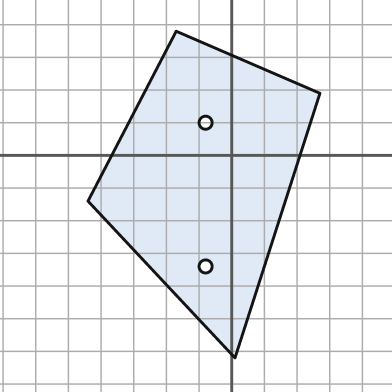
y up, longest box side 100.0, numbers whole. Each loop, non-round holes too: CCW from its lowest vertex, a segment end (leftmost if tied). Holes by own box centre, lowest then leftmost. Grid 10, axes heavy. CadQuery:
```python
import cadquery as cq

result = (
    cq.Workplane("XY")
    .moveTo(1.0, -62.0)
    .lineTo(27.0, 19.0)
    .lineTo(-17.0, 38.0)
    .lineTo(-44.0, -14.0)
    .close()
    .moveTo(-8.0, -34.0)
    .circle(2.0)
    .moveTo(-8.0, 10.0)
    .circle(2.0)
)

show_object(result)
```